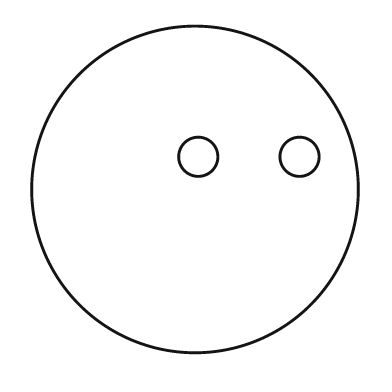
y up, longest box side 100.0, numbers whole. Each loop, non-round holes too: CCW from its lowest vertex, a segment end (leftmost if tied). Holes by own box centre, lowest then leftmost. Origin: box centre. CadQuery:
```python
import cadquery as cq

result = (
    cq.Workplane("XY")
    .moveTo(0.0, 0.0)
    .circle(50.0)
    .moveTo(1.0, 10.0)
    .circle(6.0)
    .moveTo(32.0, 10.0)
    .circle(6.0)
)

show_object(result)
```